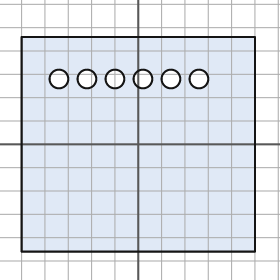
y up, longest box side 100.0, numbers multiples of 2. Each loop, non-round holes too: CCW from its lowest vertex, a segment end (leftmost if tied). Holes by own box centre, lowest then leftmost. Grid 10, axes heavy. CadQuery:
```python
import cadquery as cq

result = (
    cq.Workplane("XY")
    .moveTo(-50.0, -46.0)
    .lineTo(50.0, -46.0)
    .lineTo(50.0, 46.0)
    .lineTo(-50.0, 46.0)
    .close()
    .moveTo(-34.0, 28.0)
    .circle(4.0)
    .moveTo(-22.0, 28.0)
    .circle(4.0)
    .moveTo(-10.0, 28.0)
    .circle(4.0)
    .moveTo(2.0, 28.0)
    .circle(4.0)
    .moveTo(14.0, 28.0)
    .circle(4.0)
    .moveTo(26.0, 28.0)
    .circle(4.0)
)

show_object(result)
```